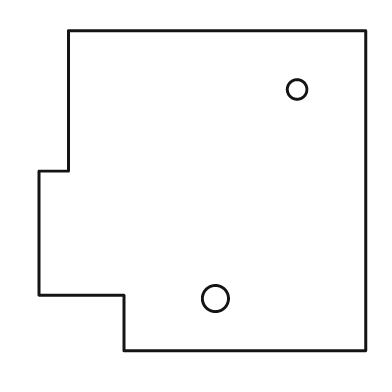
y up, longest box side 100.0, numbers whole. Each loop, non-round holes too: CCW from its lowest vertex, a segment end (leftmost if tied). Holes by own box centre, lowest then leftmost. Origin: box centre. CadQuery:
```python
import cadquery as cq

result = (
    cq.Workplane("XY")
    .moveTo(-24.0, -49.0)
    .lineTo(50.0, -49.0)
    .lineTo(50.0, 49.0)
    .lineTo(-41.0, 49.0)
    .lineTo(-41.0, 6.0)
    .lineTo(-50.0, 6.0)
    .lineTo(-50.0, -32.0)
    .lineTo(-24.0, -32.0)
    .close()
    .moveTo(4.0, -33.0)
    .circle(4.0)
    .moveTo(29.0, 31.0)
    .circle(3.0)
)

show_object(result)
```